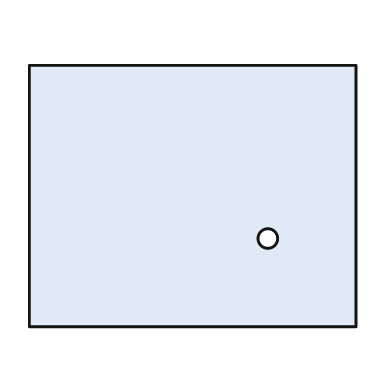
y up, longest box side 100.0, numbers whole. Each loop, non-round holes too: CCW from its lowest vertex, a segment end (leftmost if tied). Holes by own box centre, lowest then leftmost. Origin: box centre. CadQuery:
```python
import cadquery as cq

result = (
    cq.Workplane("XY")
    .moveTo(-50.0, -40.0)
    .lineTo(50.0, -40.0)
    .lineTo(50.0, 40.0)
    .lineTo(-50.0, 40.0)
    .close()
    .moveTo(23.0, -13.0)
    .circle(3.0)
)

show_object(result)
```